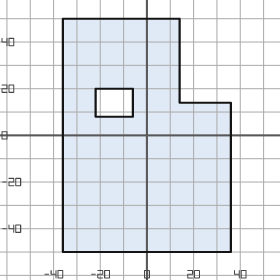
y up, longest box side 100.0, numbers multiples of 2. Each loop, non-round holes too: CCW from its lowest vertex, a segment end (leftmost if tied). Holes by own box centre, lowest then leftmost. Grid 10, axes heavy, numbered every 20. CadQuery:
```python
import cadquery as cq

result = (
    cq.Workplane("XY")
    .moveTo(-36.0, -50.0)
    .lineTo(36.0, -50.0)
    .lineTo(36.0, 14.0)
    .lineTo(14.0, 14.0)
    .lineTo(14.0, 50.0)
    .lineTo(-36.0, 50.0)
    .close()
    .moveTo(-22.0, 8.0)
    .lineTo(-6.0, 8.0)
    .lineTo(-6.0, 20.0)
    .lineTo(-22.0, 20.0)
    .close()
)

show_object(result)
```